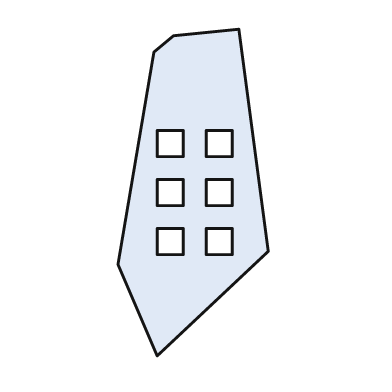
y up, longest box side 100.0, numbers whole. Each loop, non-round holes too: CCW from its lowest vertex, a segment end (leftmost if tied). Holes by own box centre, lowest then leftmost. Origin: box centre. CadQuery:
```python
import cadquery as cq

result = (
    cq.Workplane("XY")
    .moveTo(-11.0, -50.0)
    .lineTo(23.0, -18.0)
    .lineTo(14.0, 50.0)
    .lineTo(-6.0, 48.0)
    .lineTo(-12.0, 43.0)
    .lineTo(-23.0, -22.0)
    .close()
    .moveTo(-11.0, -19.0)
    .lineTo(-3.0, -19.0)
    .lineTo(-3.0, -11.0)
    .lineTo(-11.0, -11.0)
    .close()
    .moveTo(4.0, -19.0)
    .lineTo(12.0, -19.0)
    .lineTo(12.0, -11.0)
    .lineTo(4.0, -11.0)
    .close()
    .moveTo(-11.0, -4.0)
    .lineTo(-3.0, -4.0)
    .lineTo(-3.0, 4.0)
    .lineTo(-11.0, 4.0)
    .close()
    .moveTo(4.0, -4.0)
    .lineTo(12.0, -4.0)
    .lineTo(12.0, 4.0)
    .lineTo(4.0, 4.0)
    .close()
    .moveTo(-11.0, 11.0)
    .lineTo(-3.0, 11.0)
    .lineTo(-3.0, 19.0)
    .lineTo(-11.0, 19.0)
    .close()
    .moveTo(4.0, 11.0)
    .lineTo(12.0, 11.0)
    .lineTo(12.0, 19.0)
    .lineTo(4.0, 19.0)
    .close()
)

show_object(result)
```